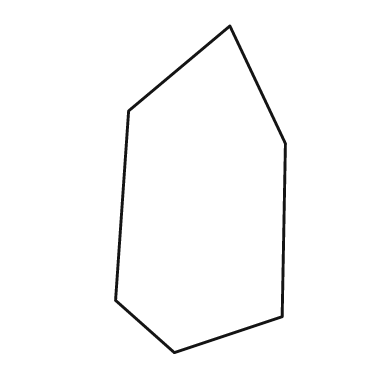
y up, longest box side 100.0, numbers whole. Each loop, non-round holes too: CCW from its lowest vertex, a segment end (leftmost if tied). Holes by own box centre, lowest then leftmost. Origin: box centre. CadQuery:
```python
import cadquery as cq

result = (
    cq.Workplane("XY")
    .moveTo(-8.0, -50.0)
    .lineTo(25.0, -39.0)
    .lineTo(26.0, 14.0)
    .lineTo(9.0, 50.0)
    .lineTo(-22.0, 24.0)
    .lineTo(-26.0, -34.0)
    .close()
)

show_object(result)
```